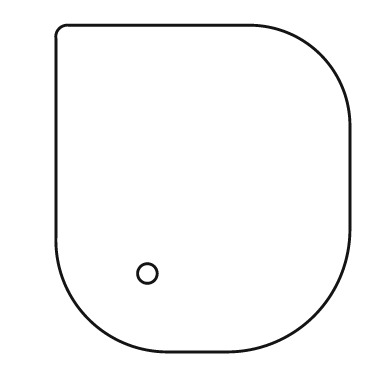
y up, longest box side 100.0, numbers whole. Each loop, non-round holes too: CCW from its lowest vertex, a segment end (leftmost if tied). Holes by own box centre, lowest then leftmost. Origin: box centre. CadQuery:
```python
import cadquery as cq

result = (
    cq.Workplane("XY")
    .moveTo(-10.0, -50.0)
    .lineTo(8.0, -50.0)
    .threePointArc((34.0, -39.0), (45.0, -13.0))
    .lineTo(45.0, 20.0)
    .threePointArc((36.0, 41.0), (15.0, 50.0))
    .lineTo(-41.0, 50.0)
    .threePointArc((-44.0, 49.0), (-45.0, 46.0))
    .lineTo(-45.0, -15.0)
    .threePointArc((-35.0, -40.0), (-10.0, -50.0))
    .close()
    .moveTo(-17.0, -26.0)
    .circle(3.0)
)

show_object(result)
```